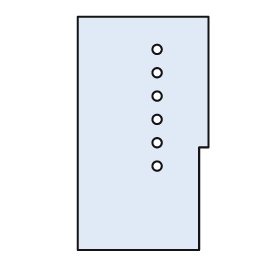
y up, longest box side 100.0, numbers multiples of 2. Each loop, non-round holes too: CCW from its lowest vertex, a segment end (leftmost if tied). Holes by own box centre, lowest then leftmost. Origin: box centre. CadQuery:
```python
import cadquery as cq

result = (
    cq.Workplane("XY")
    .moveTo(-28.0, -50.0)
    .lineTo(24.0, -50.0)
    .lineTo(24.0, -6.0)
    .lineTo(28.0, -6.0)
    .lineTo(28.0, 50.0)
    .lineTo(-28.0, 50.0)
    .close()
    .moveTo(6.0, -14.0)
    .circle(2.0)
    .moveTo(6.0, -4.0)
    .circle(2.0)
    .moveTo(6.0, 6.0)
    .circle(2.0)
    .moveTo(6.0, 16.0)
    .circle(2.0)
    .moveTo(6.0, 26.0)
    .circle(2.0)
    .moveTo(6.0, 36.0)
    .circle(2.0)
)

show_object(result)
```